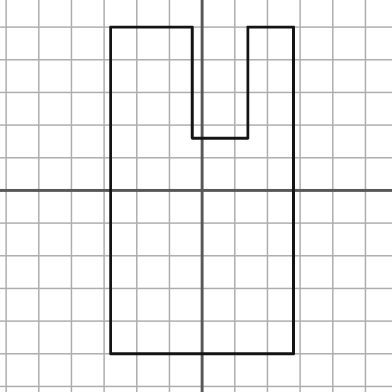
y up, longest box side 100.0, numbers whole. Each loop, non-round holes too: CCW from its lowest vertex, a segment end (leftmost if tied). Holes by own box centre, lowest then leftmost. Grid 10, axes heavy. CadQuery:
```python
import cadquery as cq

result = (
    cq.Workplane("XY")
    .moveTo(-28.0, -50.0)
    .lineTo(28.0, -50.0)
    .lineTo(28.0, 50.0)
    .lineTo(14.0, 50.0)
    .lineTo(14.0, 16.0)
    .lineTo(-3.0, 16.0)
    .lineTo(-3.0, 50.0)
    .lineTo(-28.0, 50.0)
    .close()
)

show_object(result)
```